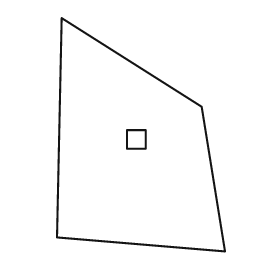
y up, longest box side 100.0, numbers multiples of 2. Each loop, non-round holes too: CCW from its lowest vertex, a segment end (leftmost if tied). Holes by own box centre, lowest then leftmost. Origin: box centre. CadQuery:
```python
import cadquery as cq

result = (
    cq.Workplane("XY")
    .moveTo(36.0, -50.0)
    .lineTo(26.0, 12.0)
    .lineTo(-34.0, 50.0)
    .lineTo(-36.0, -44.0)
    .close()
    .moveTo(-6.0, -6.0)
    .lineTo(2.0, -6.0)
    .lineTo(2.0, 2.0)
    .lineTo(-6.0, 2.0)
    .close()
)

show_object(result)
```